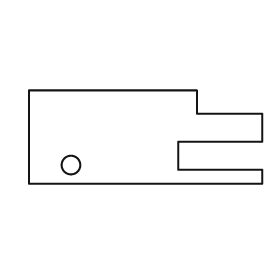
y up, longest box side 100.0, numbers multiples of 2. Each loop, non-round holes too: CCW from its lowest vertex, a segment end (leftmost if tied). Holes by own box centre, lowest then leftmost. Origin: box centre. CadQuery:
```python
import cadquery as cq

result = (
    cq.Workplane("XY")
    .moveTo(-50.0, -20.0)
    .lineTo(50.0, -20.0)
    .lineTo(50.0, -14.0)
    .lineTo(14.0, -14.0)
    .lineTo(14.0, -2.0)
    .lineTo(50.0, -2.0)
    .lineTo(50.0, 10.0)
    .lineTo(22.0, 10.0)
    .lineTo(22.0, 20.0)
    .lineTo(-50.0, 20.0)
    .close()
    .moveTo(-32.0, -12.0)
    .circle(4.0)
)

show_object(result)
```